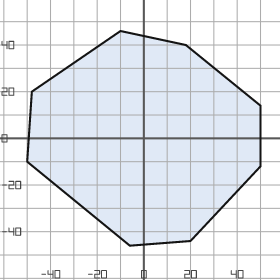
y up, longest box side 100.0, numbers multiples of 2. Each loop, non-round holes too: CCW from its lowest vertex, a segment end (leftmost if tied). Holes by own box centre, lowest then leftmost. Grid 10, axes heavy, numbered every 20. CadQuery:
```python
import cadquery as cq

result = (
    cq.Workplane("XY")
    .moveTo(-6.0, -46.0)
    .lineTo(20.0, -44.0)
    .lineTo(50.0, -12.0)
    .lineTo(50.0, 14.0)
    .lineTo(18.0, 40.0)
    .lineTo(-10.0, 46.0)
    .lineTo(-48.0, 20.0)
    .lineTo(-50.0, -10.0)
    .close()
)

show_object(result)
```